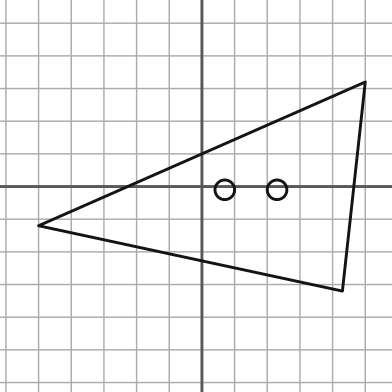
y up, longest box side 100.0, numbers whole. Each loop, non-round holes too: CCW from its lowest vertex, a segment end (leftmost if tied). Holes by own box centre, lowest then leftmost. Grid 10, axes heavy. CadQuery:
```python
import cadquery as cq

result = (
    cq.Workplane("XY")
    .moveTo(43.0, -32.0)
    .lineTo(50.0, 32.0)
    .lineTo(-50.0, -12.0)
    .close()
    .moveTo(7.0, -1.0)
    .circle(3.0)
    .moveTo(23.0, -1.0)
    .circle(3.0)
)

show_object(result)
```